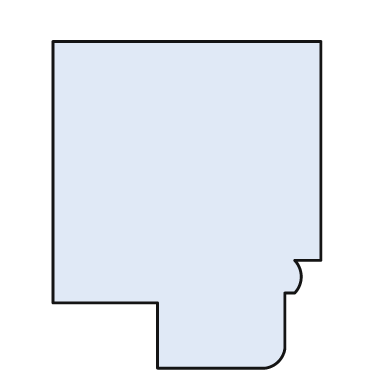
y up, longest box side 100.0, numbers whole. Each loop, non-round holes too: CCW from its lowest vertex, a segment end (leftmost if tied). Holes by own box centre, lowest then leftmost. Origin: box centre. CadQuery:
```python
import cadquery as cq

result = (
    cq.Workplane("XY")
    .moveTo(-9.0, -50.0)
    .lineTo(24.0, -50.0)
    .threePointArc((28.0, -48.0), (30.0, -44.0))
    .lineTo(30.0, -27.0)
    .lineTo(33.0, -27.0)
    .threePointArc((35.0, -22.0), (33.0, -17.0))
    .lineTo(41.0, -17.0)
    .lineTo(41.0, 50.0)
    .lineTo(-41.0, 50.0)
    .lineTo(-41.0, -30.0)
    .lineTo(-9.0, -30.0)
    .close()
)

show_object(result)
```